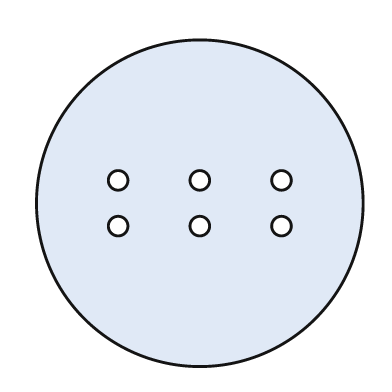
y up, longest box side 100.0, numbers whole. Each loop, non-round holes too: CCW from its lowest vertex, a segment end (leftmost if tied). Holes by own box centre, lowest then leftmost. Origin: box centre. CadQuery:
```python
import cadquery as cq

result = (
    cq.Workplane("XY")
    .moveTo(0.0, 0.0)
    .circle(50.0)
    .moveTo(-25.0, -7.0)
    .circle(3.0)
    .moveTo(0.0, -7.0)
    .circle(3.0)
    .moveTo(25.0, -7.0)
    .circle(3.0)
    .moveTo(-25.0, 7.0)
    .circle(3.0)
    .moveTo(0.0, 7.0)
    .circle(3.0)
    .moveTo(25.0, 7.0)
    .circle(3.0)
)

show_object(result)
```